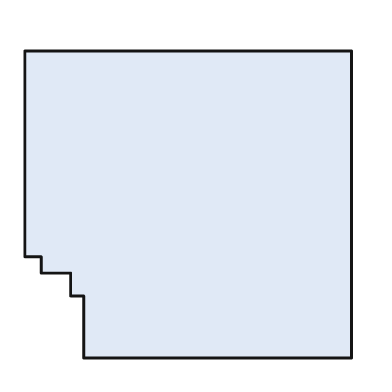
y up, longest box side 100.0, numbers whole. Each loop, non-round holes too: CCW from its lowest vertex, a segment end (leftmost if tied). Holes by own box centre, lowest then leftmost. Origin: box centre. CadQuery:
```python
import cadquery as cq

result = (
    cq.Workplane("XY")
    .moveTo(-32.0, -47.0)
    .lineTo(50.0, -47.0)
    .lineTo(50.0, 47.0)
    .lineTo(-50.0, 47.0)
    .lineTo(-50.0, -16.0)
    .lineTo(-45.0, -16.0)
    .lineTo(-45.0, -21.0)
    .lineTo(-36.0, -21.0)
    .lineTo(-36.0, -28.0)
    .lineTo(-32.0, -28.0)
    .close()
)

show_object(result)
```